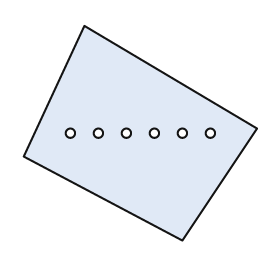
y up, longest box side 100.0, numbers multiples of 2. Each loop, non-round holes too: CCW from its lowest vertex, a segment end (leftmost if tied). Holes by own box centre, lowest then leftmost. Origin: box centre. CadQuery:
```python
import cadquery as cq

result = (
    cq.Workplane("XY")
    .moveTo(18.0, -46.0)
    .lineTo(50.0, 2.0)
    .lineTo(-24.0, 46.0)
    .lineTo(-50.0, -10.0)
    .close()
    .moveTo(-30.0, 0.0)
    .circle(2.0)
    .moveTo(-18.0, 0.0)
    .circle(2.0)
    .moveTo(-6.0, 0.0)
    .circle(2.0)
    .moveTo(6.0, 0.0)
    .circle(2.0)
    .moveTo(18.0, 0.0)
    .circle(2.0)
    .moveTo(30.0, 0.0)
    .circle(2.0)
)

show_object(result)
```